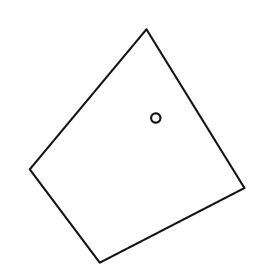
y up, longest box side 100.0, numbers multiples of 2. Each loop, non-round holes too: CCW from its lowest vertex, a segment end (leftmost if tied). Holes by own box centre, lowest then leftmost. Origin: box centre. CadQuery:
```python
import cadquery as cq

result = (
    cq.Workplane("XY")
    .moveTo(-16.0, -50.0)
    .lineTo(46.0, -18.0)
    .lineTo(4.0, 50.0)
    .lineTo(-46.0, -10.0)
    .close()
    .moveTo(8.0, 12.0)
    .circle(2.0)
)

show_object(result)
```